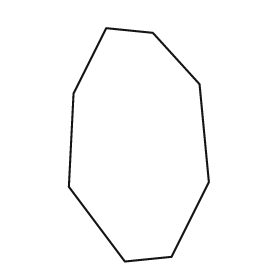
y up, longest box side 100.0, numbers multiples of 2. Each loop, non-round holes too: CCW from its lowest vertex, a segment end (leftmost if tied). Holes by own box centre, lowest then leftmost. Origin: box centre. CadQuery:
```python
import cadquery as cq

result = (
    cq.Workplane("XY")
    .moveTo(-6.0, -50.0)
    .lineTo(14.0, -48.0)
    .lineTo(30.0, -16.0)
    .lineTo(26.0, 26.0)
    .lineTo(6.0, 48.0)
    .lineTo(-14.0, 50.0)
    .lineTo(-28.0, 22.0)
    .lineTo(-30.0, -18.0)
    .close()
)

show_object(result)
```